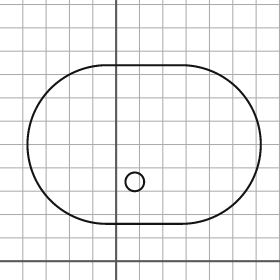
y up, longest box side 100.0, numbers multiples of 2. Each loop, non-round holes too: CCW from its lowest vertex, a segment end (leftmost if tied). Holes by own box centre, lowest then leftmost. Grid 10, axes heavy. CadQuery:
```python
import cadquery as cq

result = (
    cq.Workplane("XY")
    .moveTo(-4.0, 16.0)
    .lineTo(28.0, 16.0)
    .threePointArc((62.0, 50.0), (28.0, 84.0))
    .lineTo(-4.0, 84.0)
    .threePointArc((-38.0, 50.0), (-4.0, 16.0))
    .close()
    .moveTo(8.0, 34.0)
    .circle(4.0)
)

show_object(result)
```